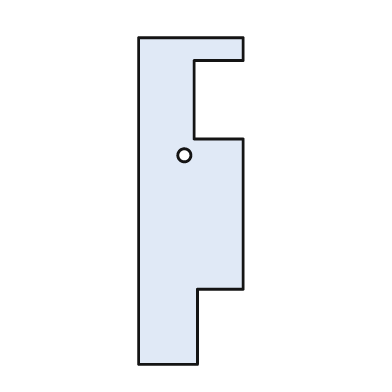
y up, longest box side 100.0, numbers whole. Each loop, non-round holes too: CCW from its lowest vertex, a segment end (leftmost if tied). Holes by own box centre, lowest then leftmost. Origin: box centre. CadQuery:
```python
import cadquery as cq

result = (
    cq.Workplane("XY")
    .moveTo(-16.0, -50.0)
    .lineTo(2.0, -50.0)
    .lineTo(2.0, -27.0)
    .lineTo(16.0, -27.0)
    .lineTo(16.0, 19.0)
    .lineTo(1.0, 19.0)
    .lineTo(1.0, 43.0)
    .lineTo(16.0, 43.0)
    .lineTo(16.0, 50.0)
    .lineTo(-16.0, 50.0)
    .close()
    .moveTo(-2.0, 14.0)
    .circle(2.0)
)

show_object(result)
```